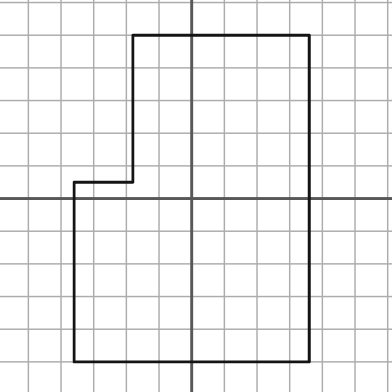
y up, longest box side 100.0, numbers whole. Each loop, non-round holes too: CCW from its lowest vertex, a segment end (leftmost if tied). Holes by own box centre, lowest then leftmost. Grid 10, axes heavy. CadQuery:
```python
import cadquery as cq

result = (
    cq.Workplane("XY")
    .moveTo(-36.0, -50.0)
    .lineTo(36.0, -50.0)
    .lineTo(36.0, 50.0)
    .lineTo(-18.0, 50.0)
    .lineTo(-18.0, 5.0)
    .lineTo(-36.0, 5.0)
    .close()
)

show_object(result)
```